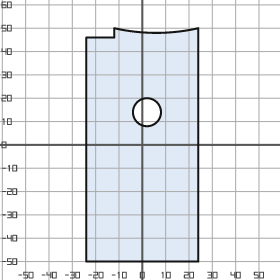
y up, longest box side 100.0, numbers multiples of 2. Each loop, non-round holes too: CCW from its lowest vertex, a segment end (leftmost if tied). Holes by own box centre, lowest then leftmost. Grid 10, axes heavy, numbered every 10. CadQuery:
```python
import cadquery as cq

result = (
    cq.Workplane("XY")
    .moveTo(-24.0, -50.0)
    .lineTo(24.0, -50.0)
    .lineTo(24.0, 50.0)
    .threePointArc((6.0, 48.0), (-12.0, 50.0))
    .lineTo(-12.0, 46.0)
    .lineTo(-24.0, 46.0)
    .close()
    .moveTo(2.0, 14.0)
    .circle(6.0)
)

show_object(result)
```